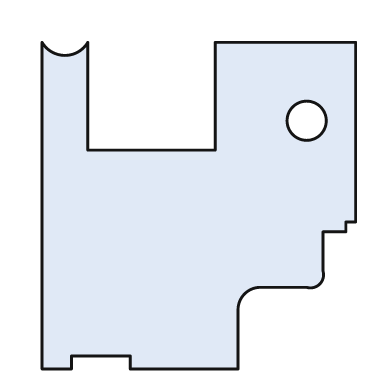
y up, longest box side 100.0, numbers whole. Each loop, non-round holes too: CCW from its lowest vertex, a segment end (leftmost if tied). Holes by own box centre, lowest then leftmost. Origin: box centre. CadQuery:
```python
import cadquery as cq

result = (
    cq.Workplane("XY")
    .moveTo(-48.0, -50.0)
    .lineTo(-39.0, -50.0)
    .lineTo(-39.0, -46.0)
    .lineTo(-21.0, -46.0)
    .lineTo(-21.0, -50.0)
    .lineTo(12.0, -50.0)
    .lineTo(12.0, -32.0)
    .threePointArc((14.0, -27.0), (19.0, -25.0))
    .lineTo(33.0, -25.0)
    .threePointArc((37.0, -24.0), (38.0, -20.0))
    .lineTo(38.0, -8.0)
    .lineTo(45.0, -8.0)
    .lineTo(45.0, -5.0)
    .lineTo(48.0, -5.0)
    .lineTo(48.0, 50.0)
    .lineTo(5.0, 50.0)
    .lineTo(5.0, 17.0)
    .lineTo(-34.0, 17.0)
    .lineTo(-34.0, 50.0)
    .threePointArc((-41.0, 46.0), (-48.0, 50.0))
    .close()
    .moveTo(33.0, 26.0)
    .circle(6.0)
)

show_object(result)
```